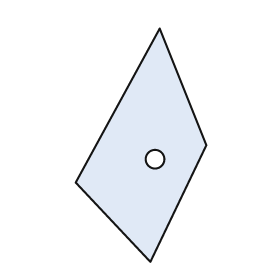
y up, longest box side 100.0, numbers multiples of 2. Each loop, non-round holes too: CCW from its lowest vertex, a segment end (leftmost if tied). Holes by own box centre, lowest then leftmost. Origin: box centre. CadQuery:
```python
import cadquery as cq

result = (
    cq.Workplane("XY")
    .moveTo(4.0, -50.0)
    .lineTo(28.0, 0.0)
    .lineTo(8.0, 50.0)
    .lineTo(-28.0, -16.0)
    .close()
    .moveTo(6.0, -6.0)
    .circle(4.0)
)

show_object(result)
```